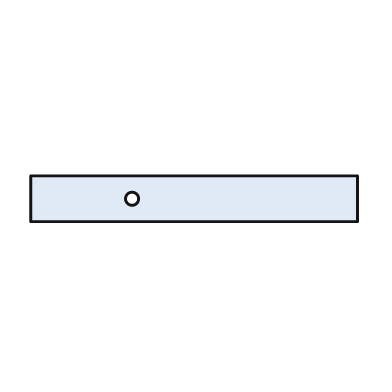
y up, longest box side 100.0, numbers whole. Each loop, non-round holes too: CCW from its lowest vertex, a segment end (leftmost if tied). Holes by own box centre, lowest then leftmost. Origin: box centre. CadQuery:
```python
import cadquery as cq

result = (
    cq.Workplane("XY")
    .moveTo(-50.0, -7.0)
    .lineTo(50.0, -7.0)
    .lineTo(50.0, 7.0)
    .lineTo(-50.0, 7.0)
    .close()
    .moveTo(-19.0, 0.0)
    .circle(2.0)
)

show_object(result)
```